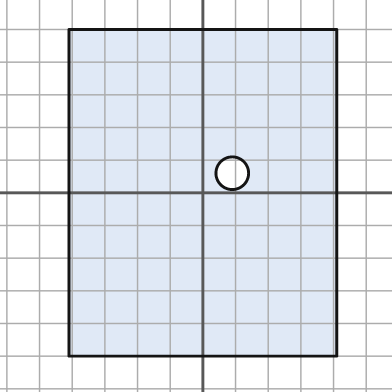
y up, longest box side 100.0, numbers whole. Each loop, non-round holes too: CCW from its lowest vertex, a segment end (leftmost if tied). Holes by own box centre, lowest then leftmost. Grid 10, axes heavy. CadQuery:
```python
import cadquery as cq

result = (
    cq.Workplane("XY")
    .moveTo(-41.0, -50.0)
    .lineTo(41.0, -50.0)
    .lineTo(41.0, 50.0)
    .lineTo(-41.0, 50.0)
    .close()
    .moveTo(9.0, 6.0)
    .circle(5.0)
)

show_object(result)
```